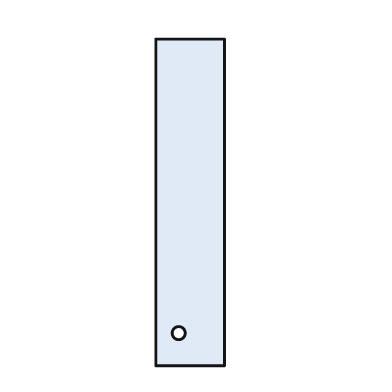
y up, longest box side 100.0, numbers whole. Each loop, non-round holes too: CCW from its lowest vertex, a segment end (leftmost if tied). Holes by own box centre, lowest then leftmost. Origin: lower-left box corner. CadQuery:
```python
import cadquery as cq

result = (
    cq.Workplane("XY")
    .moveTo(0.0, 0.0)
    .lineTo(21.0, 0.0)
    .lineTo(21.0, 100.0)
    .lineTo(0.0, 100.0)
    .close()
    .moveTo(7.0, 10.0)
    .circle(2.0)
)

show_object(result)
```